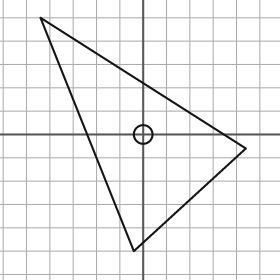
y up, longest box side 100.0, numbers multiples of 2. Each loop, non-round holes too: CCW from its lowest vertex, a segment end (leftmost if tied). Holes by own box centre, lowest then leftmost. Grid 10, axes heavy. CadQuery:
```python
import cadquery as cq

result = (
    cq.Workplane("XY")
    .moveTo(-4.0, -50.0)
    .lineTo(44.0, -6.0)
    .lineTo(-44.0, 50.0)
    .close()
    .moveTo(0.0, 0.0)
    .circle(4.0)
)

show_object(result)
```